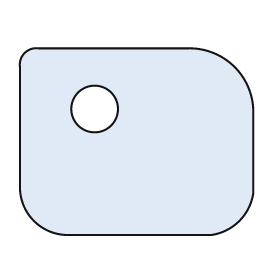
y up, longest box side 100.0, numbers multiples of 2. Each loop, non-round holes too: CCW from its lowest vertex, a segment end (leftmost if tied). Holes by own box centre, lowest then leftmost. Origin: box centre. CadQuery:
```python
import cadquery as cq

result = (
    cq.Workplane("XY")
    .moveTo(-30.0, -40.0)
    .lineTo(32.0, -40.0)
    .threePointArc((44.0, -34.0), (50.0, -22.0))
    .lineTo(50.0, 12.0)
    .threePointArc((42.0, 32.0), (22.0, 40.0))
    .lineTo(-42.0, 40.0)
    .threePointArc((-48.0, 38.0), (-50.0, 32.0))
    .lineTo(-50.0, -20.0)
    .threePointArc((-44.0, -34.0), (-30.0, -40.0))
    .close()
    .moveTo(-18.0, 14.0)
    .circle(10.0)
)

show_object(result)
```